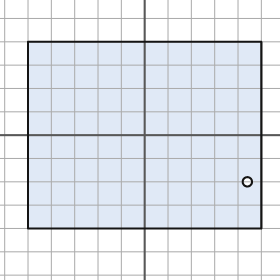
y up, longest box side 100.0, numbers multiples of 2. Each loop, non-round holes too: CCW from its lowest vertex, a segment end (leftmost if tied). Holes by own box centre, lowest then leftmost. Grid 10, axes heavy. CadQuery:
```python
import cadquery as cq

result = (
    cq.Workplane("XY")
    .moveTo(-50.0, -40.0)
    .lineTo(50.0, -40.0)
    .lineTo(50.0, 40.0)
    .lineTo(-50.0, 40.0)
    .close()
    .moveTo(44.0, -20.0)
    .circle(2.0)
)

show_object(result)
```